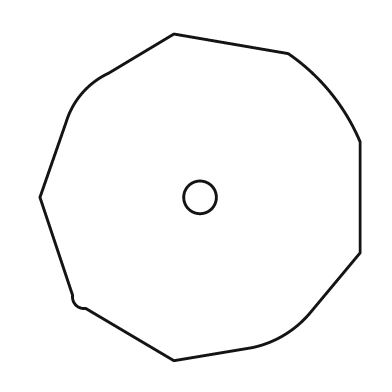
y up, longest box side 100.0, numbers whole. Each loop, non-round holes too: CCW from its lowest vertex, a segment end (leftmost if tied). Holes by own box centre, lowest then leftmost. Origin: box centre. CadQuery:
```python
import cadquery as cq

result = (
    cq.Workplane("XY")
    .moveTo(-8.0, -50.0)
    .lineTo(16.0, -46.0)
    .threePointArc((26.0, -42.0), (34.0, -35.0))
    .lineTo(49.0, -17.0)
    .lineTo(49.0, 17.0)
    .threePointArc((40.0, 32.0), (27.0, 44.0))
    .lineTo(-8.0, 50.0)
    .lineTo(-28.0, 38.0)
    .threePointArc((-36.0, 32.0), (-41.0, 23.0))
    .lineTo(-49.0, 0.0)
    .lineTo(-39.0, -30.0)
    .threePointArc((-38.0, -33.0), (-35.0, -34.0))
    .close()
    .moveTo(0.0, 0.0)
    .circle(5.0)
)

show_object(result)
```